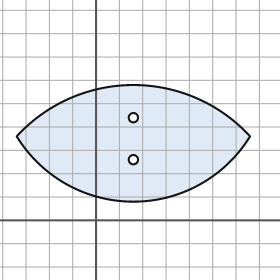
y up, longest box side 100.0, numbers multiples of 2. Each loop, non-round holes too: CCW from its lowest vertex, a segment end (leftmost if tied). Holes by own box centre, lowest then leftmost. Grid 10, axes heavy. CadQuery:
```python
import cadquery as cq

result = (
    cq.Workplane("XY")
    .moveTo(-34.0, 36.0)
    .threePointArc((16.0, 8.0), (66.0, 36.0))
    .threePointArc((16.0, 58.0), (-34.0, 36.0))
    .close()
    .moveTo(16.0, 26.0)
    .circle(2.0)
    .moveTo(16.0, 44.0)
    .circle(2.0)
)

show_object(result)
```